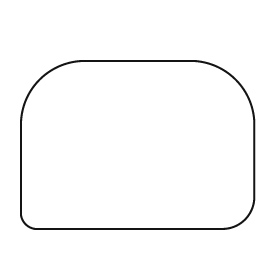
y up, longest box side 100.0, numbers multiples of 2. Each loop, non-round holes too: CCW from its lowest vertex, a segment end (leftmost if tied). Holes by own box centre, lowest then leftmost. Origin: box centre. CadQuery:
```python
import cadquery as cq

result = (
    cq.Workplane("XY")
    .moveTo(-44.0, -36.0)
    .lineTo(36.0, -36.0)
    .threePointArc((46.0, -32.0), (50.0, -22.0))
    .lineTo(50.0, 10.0)
    .threePointArc((42.0, 28.0), (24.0, 36.0))
    .lineTo(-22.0, 36.0)
    .threePointArc((-42.0, 28.0), (-50.0, 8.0))
    .lineTo(-50.0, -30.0)
    .threePointArc((-48.0, -34.0), (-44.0, -36.0))
    .close()
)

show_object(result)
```